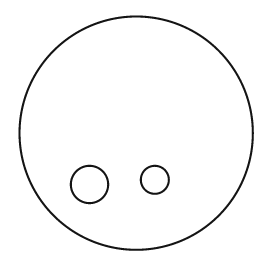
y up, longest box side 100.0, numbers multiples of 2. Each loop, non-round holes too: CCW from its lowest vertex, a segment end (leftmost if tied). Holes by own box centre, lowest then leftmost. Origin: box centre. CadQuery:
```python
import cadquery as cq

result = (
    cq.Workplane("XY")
    .moveTo(0.0, 0.0)
    .circle(50.0)
    .moveTo(-20.0, -22.0)
    .circle(8.0)
    .moveTo(8.0, -20.0)
    .circle(6.0)
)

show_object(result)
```